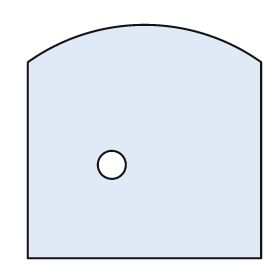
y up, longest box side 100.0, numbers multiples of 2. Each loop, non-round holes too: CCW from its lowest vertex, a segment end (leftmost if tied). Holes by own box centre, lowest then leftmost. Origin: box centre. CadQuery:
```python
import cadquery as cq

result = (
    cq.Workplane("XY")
    .moveTo(-50.0, -50.0)
    .lineTo(50.0, -50.0)
    .lineTo(50.0, 34.0)
    .threePointArc((0.0, 50.0), (-50.0, 34.0))
    .close()
    .moveTo(-14.0, -10.0)
    .circle(6.0)
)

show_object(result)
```